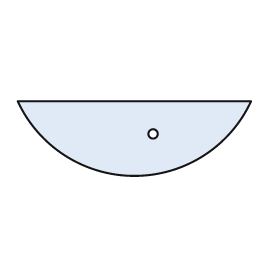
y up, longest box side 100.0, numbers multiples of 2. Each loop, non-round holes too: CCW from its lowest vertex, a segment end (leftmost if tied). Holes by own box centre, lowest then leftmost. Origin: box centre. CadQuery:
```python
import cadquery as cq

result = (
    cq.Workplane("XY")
    .moveTo(-50.0, 16.0)
    .threePointArc((0.0, -16.0), (50.0, 16.0))
    .close()
    .moveTo(8.0, 2.0)
    .circle(2.0)
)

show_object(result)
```